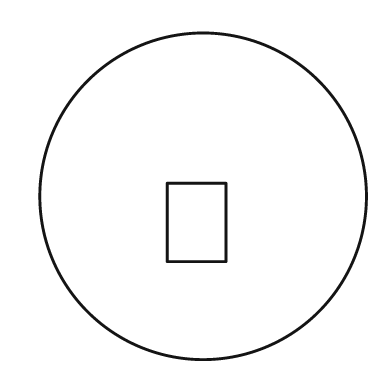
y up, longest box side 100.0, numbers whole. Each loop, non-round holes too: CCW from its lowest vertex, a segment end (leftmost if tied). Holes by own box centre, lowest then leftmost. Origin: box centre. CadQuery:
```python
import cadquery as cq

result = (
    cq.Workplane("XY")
    .moveTo(0.0, 0.0)
    .circle(50.0)
    .moveTo(-11.0, -20.0)
    .lineTo(7.0, -20.0)
    .lineTo(7.0, 4.0)
    .lineTo(-11.0, 4.0)
    .close()
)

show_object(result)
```